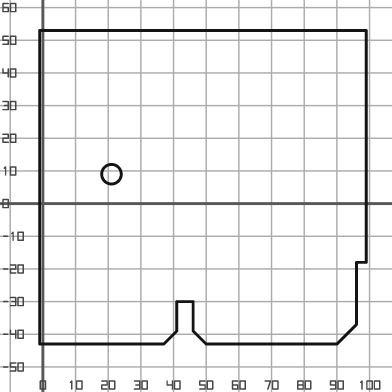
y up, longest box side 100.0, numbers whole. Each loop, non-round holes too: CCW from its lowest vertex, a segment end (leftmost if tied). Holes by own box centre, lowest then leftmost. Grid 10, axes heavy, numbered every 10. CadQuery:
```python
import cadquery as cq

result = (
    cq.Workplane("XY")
    .moveTo(-1.0, -43.0)
    .lineTo(37.0, -43.0)
    .lineTo(41.0, -39.0)
    .lineTo(41.0, -30.0)
    .lineTo(46.0, -30.0)
    .lineTo(46.0, -39.0)
    .lineTo(50.0, -43.0)
    .lineTo(90.0, -43.0)
    .lineTo(96.0, -37.0)
    .lineTo(96.0, -18.0)
    .lineTo(99.0, -18.0)
    .lineTo(99.0, 53.0)
    .lineTo(-1.0, 53.0)
    .close()
    .moveTo(21.0, 9.0)
    .circle(3.0)
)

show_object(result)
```